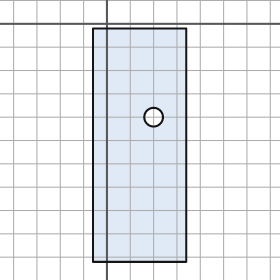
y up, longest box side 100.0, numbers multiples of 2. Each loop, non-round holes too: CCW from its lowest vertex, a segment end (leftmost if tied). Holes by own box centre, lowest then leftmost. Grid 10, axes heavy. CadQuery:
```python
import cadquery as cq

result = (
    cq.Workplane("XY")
    .moveTo(-6.0, -102.0)
    .lineTo(34.0, -102.0)
    .lineTo(34.0, -2.0)
    .lineTo(-6.0, -2.0)
    .close()
    .moveTo(20.0, -40.0)
    .circle(4.0)
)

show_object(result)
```